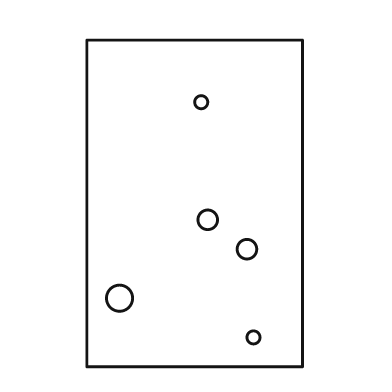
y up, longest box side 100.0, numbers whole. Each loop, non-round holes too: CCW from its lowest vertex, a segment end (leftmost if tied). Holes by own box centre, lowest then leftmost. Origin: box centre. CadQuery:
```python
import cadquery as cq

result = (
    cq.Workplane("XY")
    .moveTo(-33.0, -50.0)
    .lineTo(33.0, -50.0)
    .lineTo(33.0, 50.0)
    .lineTo(-33.0, 50.0)
    .close()
    .moveTo(18.0, -41.0)
    .circle(2.0)
    .moveTo(-23.0, -29.0)
    .circle(4.0)
    .moveTo(16.0, -14.0)
    .circle(3.0)
    .moveTo(4.0, -5.0)
    .circle(3.0)
    .moveTo(2.0, 31.0)
    .circle(2.0)
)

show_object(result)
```